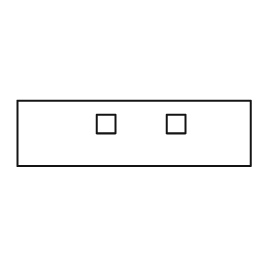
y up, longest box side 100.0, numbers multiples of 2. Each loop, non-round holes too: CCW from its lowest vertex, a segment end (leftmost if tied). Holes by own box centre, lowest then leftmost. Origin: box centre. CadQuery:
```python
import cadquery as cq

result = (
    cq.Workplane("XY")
    .moveTo(-50.0, -14.0)
    .lineTo(50.0, -14.0)
    .lineTo(50.0, 14.0)
    .lineTo(-50.0, 14.0)
    .close()
    .moveTo(-16.0, 0.0)
    .lineTo(-8.0, 0.0)
    .lineTo(-8.0, 8.0)
    .lineTo(-16.0, 8.0)
    .close()
    .moveTo(14.0, 0.0)
    .lineTo(22.0, 0.0)
    .lineTo(22.0, 8.0)
    .lineTo(14.0, 8.0)
    .close()
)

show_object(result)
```